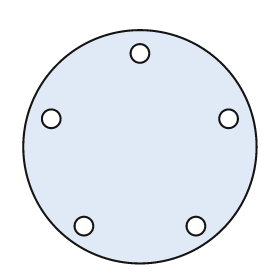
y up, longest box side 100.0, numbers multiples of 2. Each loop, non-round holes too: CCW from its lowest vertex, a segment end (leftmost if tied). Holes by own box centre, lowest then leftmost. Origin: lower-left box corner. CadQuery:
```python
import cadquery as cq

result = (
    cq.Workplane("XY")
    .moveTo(50.0, 50.0)
    .circle(50.0)
    .moveTo(26.0, 16.0)
    .circle(4.0)
    .moveTo(74.0, 16.0)
    .circle(4.0)
    .moveTo(12.0, 62.0)
    .circle(4.0)
    .moveTo(88.0, 62.0)
    .circle(4.0)
    .moveTo(50.0, 90.0)
    .circle(4.0)
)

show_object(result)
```